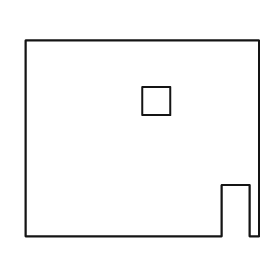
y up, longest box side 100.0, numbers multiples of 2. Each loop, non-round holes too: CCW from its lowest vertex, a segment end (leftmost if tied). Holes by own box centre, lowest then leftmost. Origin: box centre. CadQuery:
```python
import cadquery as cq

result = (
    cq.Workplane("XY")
    .moveTo(-50.0, -42.0)
    .lineTo(34.0, -42.0)
    .lineTo(34.0, -20.0)
    .lineTo(46.0, -20.0)
    .lineTo(46.0, -42.0)
    .lineTo(50.0, -42.0)
    .lineTo(50.0, 42.0)
    .lineTo(-50.0, 42.0)
    .close()
    .moveTo(0.0, 10.0)
    .lineTo(12.0, 10.0)
    .lineTo(12.0, 22.0)
    .lineTo(0.0, 22.0)
    .close()
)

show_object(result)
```